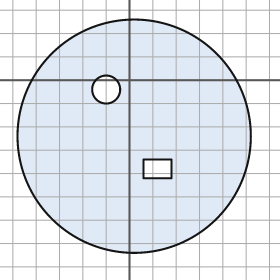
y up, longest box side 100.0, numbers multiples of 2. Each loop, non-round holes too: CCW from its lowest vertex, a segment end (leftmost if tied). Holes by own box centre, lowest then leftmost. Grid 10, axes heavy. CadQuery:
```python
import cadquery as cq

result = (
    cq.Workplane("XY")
    .moveTo(2.0, -24.0)
    .circle(50.0)
    .moveTo(6.0, -42.0)
    .lineTo(18.0, -42.0)
    .lineTo(18.0, -34.0)
    .lineTo(6.0, -34.0)
    .close()
    .moveTo(-10.0, -4.0)
    .circle(6.0)
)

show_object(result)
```